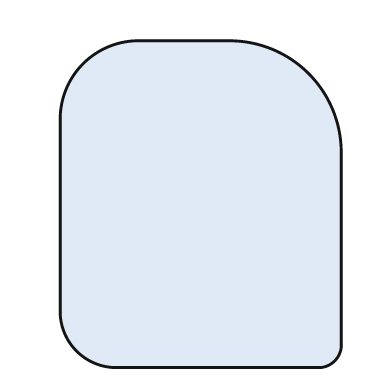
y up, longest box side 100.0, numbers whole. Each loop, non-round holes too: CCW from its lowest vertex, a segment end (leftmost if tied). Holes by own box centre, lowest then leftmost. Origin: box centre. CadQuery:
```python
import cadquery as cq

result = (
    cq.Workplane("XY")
    .moveTo(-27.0, -50.0)
    .lineTo(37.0, -50.0)
    .threePointArc((41.0, -48.0), (43.0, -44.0))
    .lineTo(43.0, 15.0)
    .threePointArc((33.0, 40.0), (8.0, 50.0))
    .lineTo(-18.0, 50.0)
    .threePointArc((-36.0, 43.0), (-43.0, 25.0))
    .lineTo(-43.0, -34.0)
    .threePointArc((-38.0, -45.0), (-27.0, -50.0))
    .close()
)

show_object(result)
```